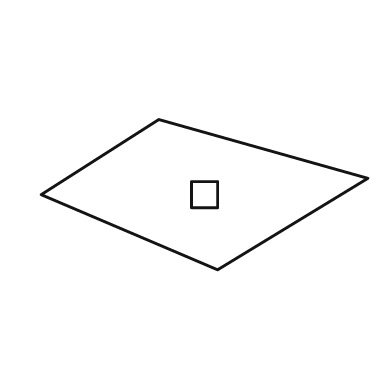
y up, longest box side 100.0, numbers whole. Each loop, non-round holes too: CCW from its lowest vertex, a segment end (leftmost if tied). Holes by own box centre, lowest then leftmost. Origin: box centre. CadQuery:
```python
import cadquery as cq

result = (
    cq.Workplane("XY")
    .moveTo(4.0, -23.0)
    .lineTo(50.0, 5.0)
    .lineTo(-14.0, 23.0)
    .lineTo(-50.0, 0.0)
    .close()
    .moveTo(-4.0, -4.0)
    .lineTo(4.0, -4.0)
    .lineTo(4.0, 4.0)
    .lineTo(-4.0, 4.0)
    .close()
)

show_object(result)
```